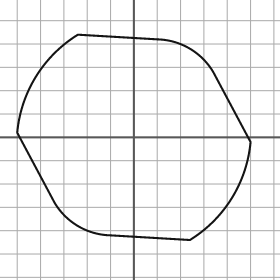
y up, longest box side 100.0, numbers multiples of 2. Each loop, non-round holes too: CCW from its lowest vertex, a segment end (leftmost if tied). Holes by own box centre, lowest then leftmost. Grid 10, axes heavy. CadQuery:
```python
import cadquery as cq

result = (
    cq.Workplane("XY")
    .moveTo(24.0, -44.0)
    .threePointArc((42.0, -26.0), (50.0, -2.0))
    .lineTo(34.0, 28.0)
    .threePointArc((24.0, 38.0), (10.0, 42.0))
    .lineTo(-24.0, 44.0)
    .threePointArc((-42.0, 26.0), (-50.0, 2.0))
    .lineTo(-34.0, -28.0)
    .threePointArc((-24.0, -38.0), (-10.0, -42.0))
    .close()
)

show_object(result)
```